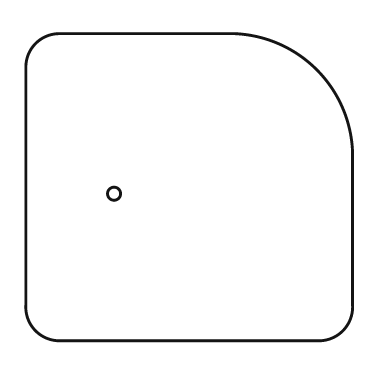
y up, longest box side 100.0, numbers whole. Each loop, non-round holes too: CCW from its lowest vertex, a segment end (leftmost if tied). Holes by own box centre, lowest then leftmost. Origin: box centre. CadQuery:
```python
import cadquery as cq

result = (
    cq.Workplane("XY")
    .moveTo(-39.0, -47.0)
    .lineTo(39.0, -47.0)
    .threePointArc((47.0, -44.0), (50.0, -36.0))
    .lineTo(50.0, 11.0)
    .threePointArc((39.0, 36.0), (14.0, 47.0))
    .lineTo(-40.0, 47.0)
    .threePointArc((-47.0, 44.0), (-50.0, 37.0))
    .lineTo(-50.0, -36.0)
    .threePointArc((-47.0, -44.0), (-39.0, -47.0))
    .close()
    .moveTo(-23.0, -2.0)
    .circle(2.0)
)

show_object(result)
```